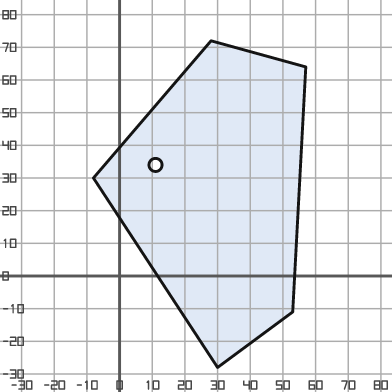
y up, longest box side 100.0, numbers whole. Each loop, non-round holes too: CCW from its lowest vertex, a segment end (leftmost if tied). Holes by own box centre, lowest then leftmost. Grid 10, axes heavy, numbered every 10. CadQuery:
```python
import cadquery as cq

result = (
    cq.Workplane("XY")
    .moveTo(30.0, -28.0)
    .lineTo(53.0, -11.0)
    .lineTo(57.0, 64.0)
    .lineTo(28.0, 72.0)
    .lineTo(-8.0, 30.0)
    .close()
    .moveTo(11.0, 34.0)
    .circle(2.0)
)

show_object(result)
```